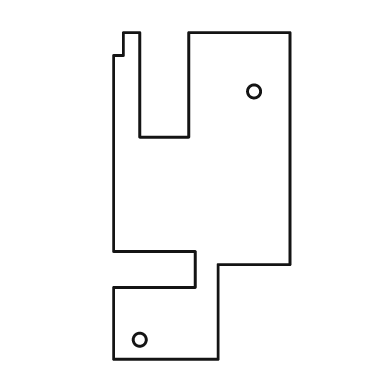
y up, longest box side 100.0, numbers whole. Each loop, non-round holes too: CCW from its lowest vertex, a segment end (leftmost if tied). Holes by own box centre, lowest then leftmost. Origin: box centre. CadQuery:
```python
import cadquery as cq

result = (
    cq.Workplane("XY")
    .moveTo(-27.0, -50.0)
    .lineTo(5.0, -50.0)
    .lineTo(5.0, -21.0)
    .lineTo(27.0, -21.0)
    .lineTo(27.0, 50.0)
    .lineTo(-4.0, 50.0)
    .lineTo(-4.0, 18.0)
    .lineTo(-19.0, 18.0)
    .lineTo(-19.0, 50.0)
    .lineTo(-24.0, 50.0)
    .lineTo(-24.0, 43.0)
    .lineTo(-27.0, 43.0)
    .lineTo(-27.0, -17.0)
    .lineTo(-2.0, -17.0)
    .lineTo(-2.0, -28.0)
    .lineTo(-27.0, -28.0)
    .close()
    .moveTo(-19.0, -44.0)
    .circle(2.0)
    .moveTo(16.0, 32.0)
    .circle(2.0)
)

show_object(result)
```